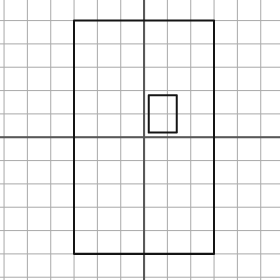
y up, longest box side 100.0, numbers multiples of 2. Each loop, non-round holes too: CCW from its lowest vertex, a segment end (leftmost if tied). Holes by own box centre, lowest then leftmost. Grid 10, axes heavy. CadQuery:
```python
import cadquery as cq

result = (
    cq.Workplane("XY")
    .moveTo(-30.0, -50.0)
    .lineTo(30.0, -50.0)
    .lineTo(30.0, 50.0)
    .lineTo(-30.0, 50.0)
    .close()
    .moveTo(2.0, 2.0)
    .lineTo(14.0, 2.0)
    .lineTo(14.0, 18.0)
    .lineTo(2.0, 18.0)
    .close()
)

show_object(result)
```